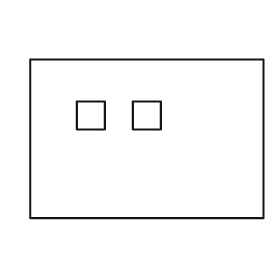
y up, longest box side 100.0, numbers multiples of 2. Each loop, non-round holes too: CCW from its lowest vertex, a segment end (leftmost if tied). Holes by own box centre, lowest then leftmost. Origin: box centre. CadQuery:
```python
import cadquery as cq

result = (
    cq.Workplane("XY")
    .moveTo(-50.0, -34.0)
    .lineTo(50.0, -34.0)
    .lineTo(50.0, 34.0)
    .lineTo(-50.0, 34.0)
    .close()
    .moveTo(-30.0, 4.0)
    .lineTo(-18.0, 4.0)
    .lineTo(-18.0, 16.0)
    .lineTo(-30.0, 16.0)
    .close()
    .moveTo(-6.0, 4.0)
    .lineTo(6.0, 4.0)
    .lineTo(6.0, 16.0)
    .lineTo(-6.0, 16.0)
    .close()
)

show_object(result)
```